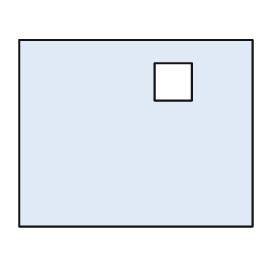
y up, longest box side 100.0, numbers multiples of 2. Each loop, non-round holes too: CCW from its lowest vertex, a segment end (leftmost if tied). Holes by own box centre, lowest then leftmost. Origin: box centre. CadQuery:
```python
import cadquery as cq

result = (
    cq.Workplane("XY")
    .moveTo(-50.0, -40.0)
    .lineTo(50.0, -40.0)
    .lineTo(50.0, 40.0)
    .lineTo(-50.0, 40.0)
    .close()
    .moveTo(8.0, 14.0)
    .lineTo(24.0, 14.0)
    .lineTo(24.0, 30.0)
    .lineTo(8.0, 30.0)
    .close()
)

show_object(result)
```